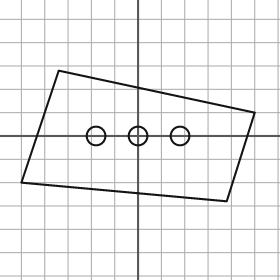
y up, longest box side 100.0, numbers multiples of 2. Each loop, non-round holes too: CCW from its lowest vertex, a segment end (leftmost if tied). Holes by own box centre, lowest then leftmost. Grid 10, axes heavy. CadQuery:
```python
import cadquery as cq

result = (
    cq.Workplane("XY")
    .moveTo(38.0, -28.0)
    .lineTo(50.0, 10.0)
    .lineTo(-34.0, 28.0)
    .lineTo(-50.0, -20.0)
    .close()
    .moveTo(-18.0, 0.0)
    .circle(4.0)
    .moveTo(0.0, 0.0)
    .circle(4.0)
    .moveTo(18.0, 0.0)
    .circle(4.0)
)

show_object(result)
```